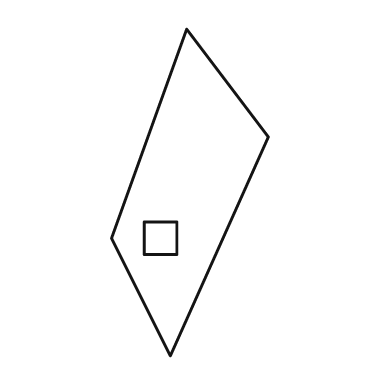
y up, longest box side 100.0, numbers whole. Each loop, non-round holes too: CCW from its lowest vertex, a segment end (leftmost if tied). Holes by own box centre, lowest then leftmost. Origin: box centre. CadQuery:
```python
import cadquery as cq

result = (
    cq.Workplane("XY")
    .moveTo(-6.0, -50.0)
    .lineTo(24.0, 17.0)
    .lineTo(-1.0, 50.0)
    .lineTo(-24.0, -14.0)
    .close()
    .moveTo(-14.0, -19.0)
    .lineTo(-4.0, -19.0)
    .lineTo(-4.0, -9.0)
    .lineTo(-14.0, -9.0)
    .close()
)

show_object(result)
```